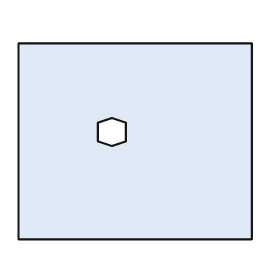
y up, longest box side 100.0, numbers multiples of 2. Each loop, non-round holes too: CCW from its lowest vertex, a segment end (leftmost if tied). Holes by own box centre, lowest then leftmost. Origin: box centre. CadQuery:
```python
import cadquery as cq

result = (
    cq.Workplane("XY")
    .moveTo(-50.0, -42.0)
    .lineTo(50.0, -42.0)
    .lineTo(50.0, 42.0)
    .lineTo(-50.0, 42.0)
    .close()
    .moveTo(-10.0, -2.0)
    .lineTo(-4.0, 0.0)
    .lineTo(-4.0, 8.0)
    .lineTo(-10.0, 10.0)
    .lineTo(-16.0, 8.0)
    .lineTo(-16.0, 0.0)
    .close()
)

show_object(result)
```